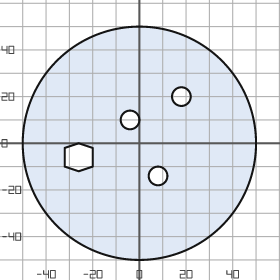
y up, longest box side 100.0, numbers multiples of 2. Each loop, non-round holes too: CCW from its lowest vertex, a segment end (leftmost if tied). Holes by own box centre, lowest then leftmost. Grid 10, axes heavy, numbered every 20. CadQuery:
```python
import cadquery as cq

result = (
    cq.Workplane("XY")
    .moveTo(0.0, 0.0)
    .circle(50.0)
    .moveTo(8.0, -14.0)
    .circle(4.0)
    .moveTo(-26.0, -12.0)
    .lineTo(-20.0, -10.0)
    .lineTo(-20.0, -2.0)
    .lineTo(-26.0, 0.0)
    .lineTo(-32.0, -2.0)
    .lineTo(-32.0, -10.0)
    .close()
    .moveTo(-4.0, 10.0)
    .circle(4.0)
    .moveTo(18.0, 20.0)
    .circle(4.0)
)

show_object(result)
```